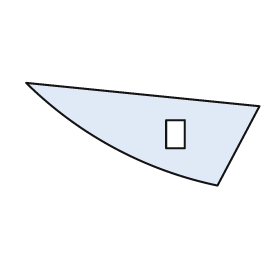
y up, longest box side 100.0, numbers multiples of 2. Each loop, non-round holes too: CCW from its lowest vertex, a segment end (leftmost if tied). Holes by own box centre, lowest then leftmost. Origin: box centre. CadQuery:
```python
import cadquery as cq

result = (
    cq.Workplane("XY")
    .moveTo(32.0, -22.0)
    .lineTo(50.0, 12.0)
    .lineTo(-50.0, 22.0)
    .threePointArc((-12.0, -6.0), (32.0, -22.0))
    .close()
    .moveTo(10.0, -6.0)
    .lineTo(18.0, -6.0)
    .lineTo(18.0, 6.0)
    .lineTo(10.0, 6.0)
    .close()
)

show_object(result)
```